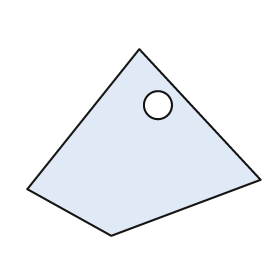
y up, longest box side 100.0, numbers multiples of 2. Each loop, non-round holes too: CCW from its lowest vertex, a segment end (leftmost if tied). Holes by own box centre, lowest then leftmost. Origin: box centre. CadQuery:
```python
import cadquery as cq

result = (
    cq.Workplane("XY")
    .moveTo(-14.0, -40.0)
    .lineTo(50.0, -16.0)
    .lineTo(-2.0, 40.0)
    .lineTo(-50.0, -20.0)
    .close()
    .moveTo(6.0, 16.0)
    .circle(6.0)
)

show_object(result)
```